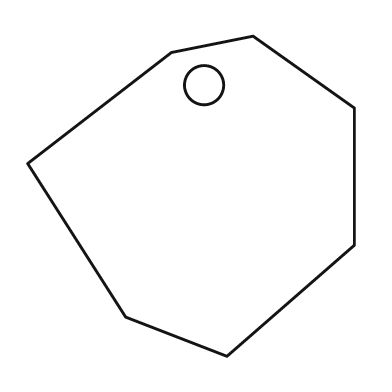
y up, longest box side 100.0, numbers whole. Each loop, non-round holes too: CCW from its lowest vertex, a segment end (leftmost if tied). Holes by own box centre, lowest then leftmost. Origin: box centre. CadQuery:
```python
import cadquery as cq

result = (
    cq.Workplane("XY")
    .moveTo(11.0, -49.0)
    .lineTo(50.0, -15.0)
    .lineTo(50.0, 27.0)
    .lineTo(19.0, 49.0)
    .lineTo(-6.0, 44.0)
    .lineTo(-50.0, 10.0)
    .lineTo(-20.0, -37.0)
    .close()
    .moveTo(4.0, 34.0)
    .circle(6.0)
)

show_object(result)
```